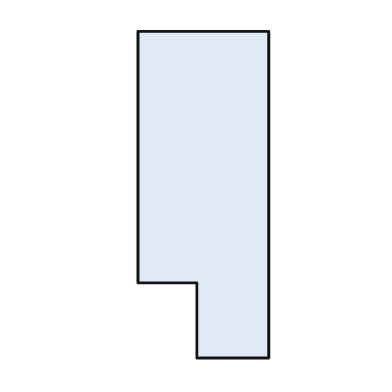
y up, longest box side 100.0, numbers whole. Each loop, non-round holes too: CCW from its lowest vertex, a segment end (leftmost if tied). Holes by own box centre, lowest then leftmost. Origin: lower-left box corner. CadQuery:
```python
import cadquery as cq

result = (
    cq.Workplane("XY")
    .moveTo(18.0, 0.0)
    .lineTo(40.0, 0.0)
    .lineTo(40.0, 100.0)
    .lineTo(0.0, 100.0)
    .lineTo(0.0, 23.0)
    .lineTo(18.0, 23.0)
    .close()
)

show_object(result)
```